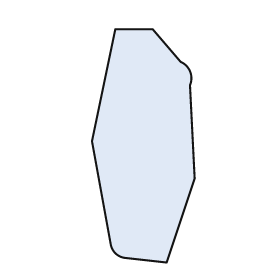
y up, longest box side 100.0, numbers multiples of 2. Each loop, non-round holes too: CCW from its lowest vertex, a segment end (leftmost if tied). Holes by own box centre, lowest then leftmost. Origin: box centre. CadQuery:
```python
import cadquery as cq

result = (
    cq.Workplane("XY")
    .moveTo(10.0, -50.0)
    .lineTo(22.0, -14.0)
    .lineTo(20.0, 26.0)
    .threePointArc((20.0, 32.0), (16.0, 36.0))
    .lineTo(4.0, 50.0)
    .lineTo(-12.0, 50.0)
    .lineTo(-22.0, 2.0)
    .lineTo(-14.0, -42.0)
    .threePointArc((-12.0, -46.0), (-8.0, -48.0))
    .close()
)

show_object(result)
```